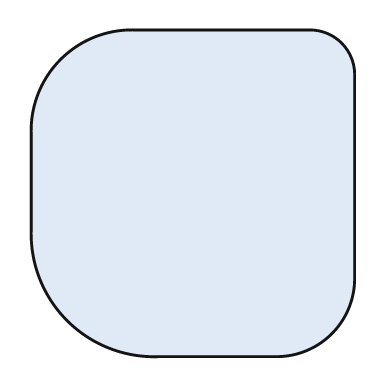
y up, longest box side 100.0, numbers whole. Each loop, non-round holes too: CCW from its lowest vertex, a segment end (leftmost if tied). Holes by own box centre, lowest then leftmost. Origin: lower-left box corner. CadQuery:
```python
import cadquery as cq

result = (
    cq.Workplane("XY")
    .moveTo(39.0, 0.0)
    .lineTo(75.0, 0.0)
    .threePointArc((92.0, 7.0), (99.0, 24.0))
    .lineTo(99.0, 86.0)
    .threePointArc((95.0, 96.0), (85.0, 100.0))
    .lineTo(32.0, 100.0)
    .threePointArc((9.0, 91.0), (0.0, 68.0))
    .lineTo(0.0, 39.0)
    .threePointArc((11.0, 11.0), (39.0, 0.0))
    .close()
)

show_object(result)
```